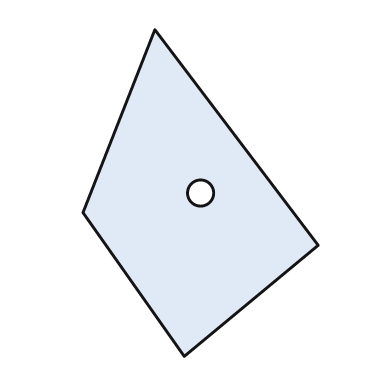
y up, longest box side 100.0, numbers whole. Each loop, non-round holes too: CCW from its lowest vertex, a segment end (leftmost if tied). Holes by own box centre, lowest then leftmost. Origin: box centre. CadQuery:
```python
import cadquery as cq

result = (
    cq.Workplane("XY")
    .moveTo(-5.0, -50.0)
    .lineTo(36.0, -16.0)
    .lineTo(-14.0, 50.0)
    .lineTo(-36.0, -6.0)
    .close()
    .moveTo(0.0, 0.0)
    .circle(4.0)
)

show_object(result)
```